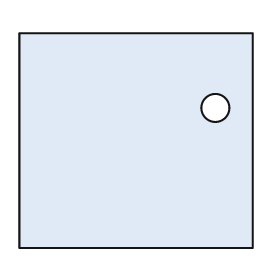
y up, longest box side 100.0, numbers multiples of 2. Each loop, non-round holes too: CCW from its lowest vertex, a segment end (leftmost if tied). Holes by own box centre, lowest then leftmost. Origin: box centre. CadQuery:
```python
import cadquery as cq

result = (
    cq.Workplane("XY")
    .moveTo(-50.0, -46.0)
    .lineTo(50.0, -46.0)
    .lineTo(50.0, 46.0)
    .lineTo(-50.0, 46.0)
    .close()
    .moveTo(34.0, 14.0)
    .circle(6.0)
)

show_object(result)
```